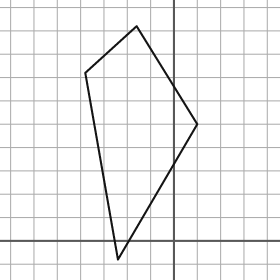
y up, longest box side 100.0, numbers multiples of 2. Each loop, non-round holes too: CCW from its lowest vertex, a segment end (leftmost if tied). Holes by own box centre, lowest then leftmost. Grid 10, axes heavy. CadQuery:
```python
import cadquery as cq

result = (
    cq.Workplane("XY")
    .moveTo(-24.0, -8.0)
    .lineTo(10.0, 50.0)
    .lineTo(-16.0, 92.0)
    .lineTo(-38.0, 72.0)
    .close()
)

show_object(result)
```